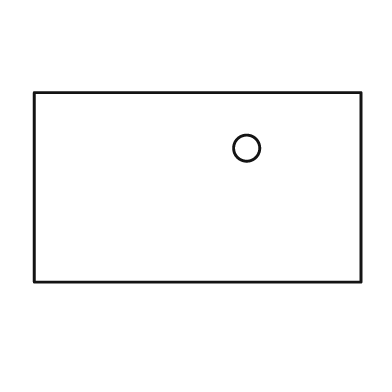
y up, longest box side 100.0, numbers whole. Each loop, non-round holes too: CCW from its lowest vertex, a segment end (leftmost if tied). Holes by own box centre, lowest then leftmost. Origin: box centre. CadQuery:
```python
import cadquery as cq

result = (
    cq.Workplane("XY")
    .moveTo(-50.0, -29.0)
    .lineTo(50.0, -29.0)
    .lineTo(50.0, 29.0)
    .lineTo(-50.0, 29.0)
    .close()
    .moveTo(15.0, 12.0)
    .circle(4.0)
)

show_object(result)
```